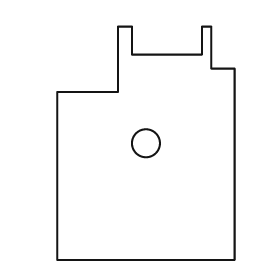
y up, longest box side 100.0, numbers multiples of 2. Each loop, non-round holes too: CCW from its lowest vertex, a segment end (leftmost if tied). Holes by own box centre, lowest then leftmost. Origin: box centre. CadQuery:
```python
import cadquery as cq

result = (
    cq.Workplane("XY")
    .moveTo(-38.0, -50.0)
    .lineTo(38.0, -50.0)
    .lineTo(38.0, 32.0)
    .lineTo(28.0, 32.0)
    .lineTo(28.0, 50.0)
    .lineTo(24.0, 50.0)
    .lineTo(24.0, 38.0)
    .lineTo(-6.0, 38.0)
    .lineTo(-6.0, 50.0)
    .lineTo(-12.0, 50.0)
    .lineTo(-12.0, 22.0)
    .lineTo(-38.0, 22.0)
    .close()
    .moveTo(0.0, 0.0)
    .circle(6.0)
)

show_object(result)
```